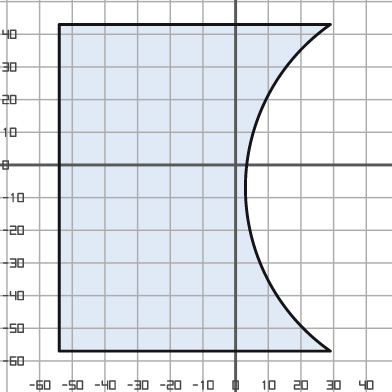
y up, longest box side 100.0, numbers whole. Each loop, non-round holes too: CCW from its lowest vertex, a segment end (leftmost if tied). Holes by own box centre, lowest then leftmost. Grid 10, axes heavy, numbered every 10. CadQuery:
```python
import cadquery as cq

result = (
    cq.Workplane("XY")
    .moveTo(-54.0, -57.0)
    .lineTo(29.0, -57.0)
    .threePointArc((3.0, -7.0), (29.0, 43.0))
    .lineTo(-54.0, 43.0)
    .close()
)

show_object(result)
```